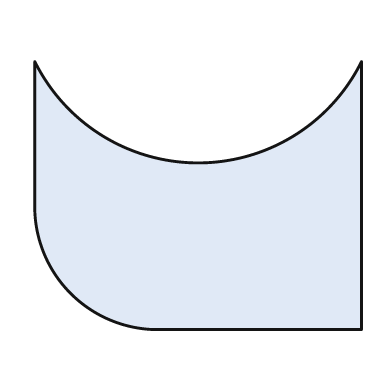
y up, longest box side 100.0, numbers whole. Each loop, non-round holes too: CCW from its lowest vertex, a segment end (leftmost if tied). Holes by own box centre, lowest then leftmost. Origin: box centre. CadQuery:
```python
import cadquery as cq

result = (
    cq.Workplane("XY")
    .moveTo(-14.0, -41.0)
    .lineTo(50.0, -41.0)
    .lineTo(50.0, 41.0)
    .threePointArc((0.0, 10.0), (-50.0, 41.0))
    .lineTo(-50.0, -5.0)
    .threePointArc((-39.0, -30.0), (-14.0, -41.0))
    .close()
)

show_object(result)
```